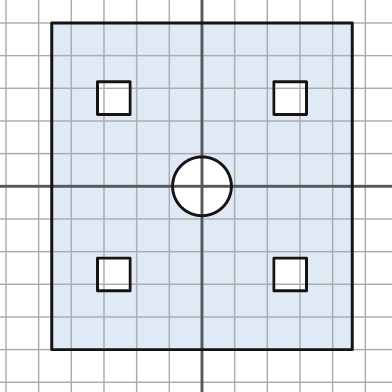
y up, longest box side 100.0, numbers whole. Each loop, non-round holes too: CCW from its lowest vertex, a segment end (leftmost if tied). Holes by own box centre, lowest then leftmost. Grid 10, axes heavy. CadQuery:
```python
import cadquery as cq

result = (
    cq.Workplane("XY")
    .moveTo(-46.0, -50.0)
    .lineTo(46.0, -50.0)
    .lineTo(46.0, 50.0)
    .lineTo(-46.0, 50.0)
    .close()
    .moveTo(-32.0, -32.0)
    .lineTo(-22.0, -32.0)
    .lineTo(-22.0, -22.0)
    .lineTo(-32.0, -22.0)
    .close()
    .moveTo(22.0, -32.0)
    .lineTo(32.0, -32.0)
    .lineTo(32.0, -22.0)
    .lineTo(22.0, -22.0)
    .close()
    .moveTo(0.0, 0.0)
    .circle(9.0)
    .moveTo(-32.0, 22.0)
    .lineTo(-22.0, 22.0)
    .lineTo(-22.0, 32.0)
    .lineTo(-32.0, 32.0)
    .close()
    .moveTo(22.0, 22.0)
    .lineTo(32.0, 22.0)
    .lineTo(32.0, 32.0)
    .lineTo(22.0, 32.0)
    .close()
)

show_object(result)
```